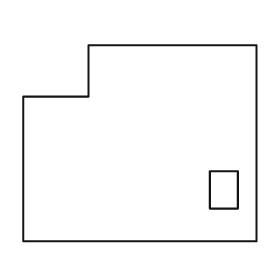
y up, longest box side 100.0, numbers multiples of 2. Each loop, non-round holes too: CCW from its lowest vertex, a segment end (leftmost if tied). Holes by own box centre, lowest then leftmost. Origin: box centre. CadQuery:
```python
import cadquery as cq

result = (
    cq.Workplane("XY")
    .moveTo(-50.0, -42.0)
    .lineTo(50.0, -42.0)
    .lineTo(50.0, 42.0)
    .lineTo(-22.0, 42.0)
    .lineTo(-22.0, 20.0)
    .lineTo(-50.0, 20.0)
    .close()
    .moveTo(30.0, -28.0)
    .lineTo(42.0, -28.0)
    .lineTo(42.0, -12.0)
    .lineTo(30.0, -12.0)
    .close()
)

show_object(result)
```